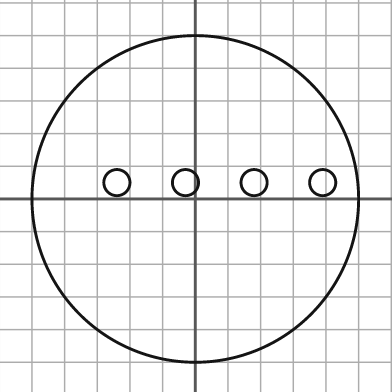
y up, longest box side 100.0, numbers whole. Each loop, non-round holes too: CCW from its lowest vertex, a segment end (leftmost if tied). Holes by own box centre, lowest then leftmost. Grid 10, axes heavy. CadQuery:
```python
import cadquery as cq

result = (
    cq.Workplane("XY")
    .moveTo(0.0, 0.0)
    .circle(50.0)
    .moveTo(-24.0, 5.0)
    .circle(4.0)
    .moveTo(-3.0, 5.0)
    .circle(4.0)
    .moveTo(18.0, 5.0)
    .circle(4.0)
    .moveTo(39.0, 5.0)
    .circle(4.0)
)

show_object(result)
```